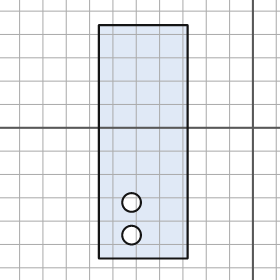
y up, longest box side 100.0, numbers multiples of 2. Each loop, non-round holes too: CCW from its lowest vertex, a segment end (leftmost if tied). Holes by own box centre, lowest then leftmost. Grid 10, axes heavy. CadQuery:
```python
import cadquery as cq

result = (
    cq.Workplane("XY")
    .moveTo(-66.0, -56.0)
    .lineTo(-28.0, -56.0)
    .lineTo(-28.0, 44.0)
    .lineTo(-66.0, 44.0)
    .close()
    .moveTo(-52.0, -46.0)
    .circle(4.0)
    .moveTo(-52.0, -32.0)
    .circle(4.0)
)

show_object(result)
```